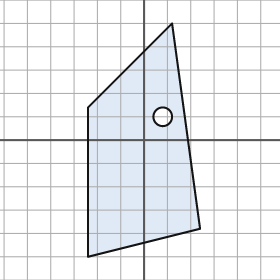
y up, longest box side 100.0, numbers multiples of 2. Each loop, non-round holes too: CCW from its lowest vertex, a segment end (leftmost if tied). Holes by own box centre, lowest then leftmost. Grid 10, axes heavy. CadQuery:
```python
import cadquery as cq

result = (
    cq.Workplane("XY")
    .moveTo(-24.0, -50.0)
    .lineTo(24.0, -38.0)
    .lineTo(12.0, 50.0)
    .lineTo(-24.0, 14.0)
    .close()
    .moveTo(8.0, 10.0)
    .circle(4.0)
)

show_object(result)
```